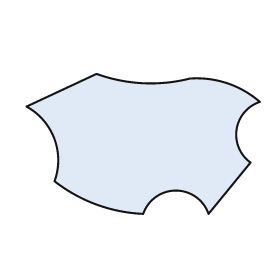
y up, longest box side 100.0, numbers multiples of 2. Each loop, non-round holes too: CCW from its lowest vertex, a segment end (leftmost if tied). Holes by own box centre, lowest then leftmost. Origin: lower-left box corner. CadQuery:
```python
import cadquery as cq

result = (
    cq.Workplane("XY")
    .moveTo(50.0, 0.0)
    .threePointArc((64.0, 10.0), (78.0, 0.0))
    .lineTo(96.0, 22.0)
    .threePointArc((90.0, 36.0), (100.0, 48.0))
    .threePointArc((86.0, 56.0), (70.0, 58.0))
    .threePointArc((50.0, 56.0), (30.0, 60.0))
    .lineTo(0.0, 46.0)
    .threePointArc((12.0, 32.0), (12.0, 14.0))
    .threePointArc((30.0, 4.0), (50.0, 0.0))
    .close()
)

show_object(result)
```